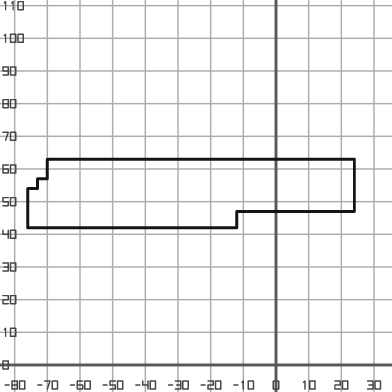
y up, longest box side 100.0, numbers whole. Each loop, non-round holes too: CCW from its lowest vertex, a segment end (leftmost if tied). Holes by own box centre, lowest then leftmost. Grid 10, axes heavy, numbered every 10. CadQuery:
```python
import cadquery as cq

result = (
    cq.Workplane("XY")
    .moveTo(-76.0, 42.0)
    .lineTo(-12.0, 42.0)
    .lineTo(-12.0, 47.0)
    .lineTo(24.0, 47.0)
    .lineTo(24.0, 63.0)
    .lineTo(-70.0, 63.0)
    .lineTo(-70.0, 57.0)
    .lineTo(-73.0, 57.0)
    .lineTo(-73.0, 54.0)
    .lineTo(-76.0, 54.0)
    .close()
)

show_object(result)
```